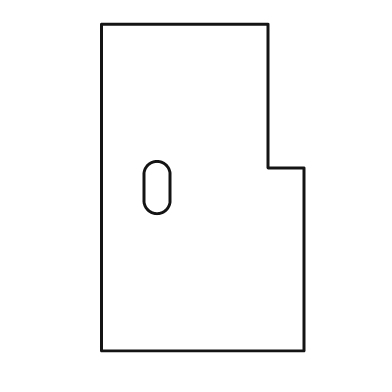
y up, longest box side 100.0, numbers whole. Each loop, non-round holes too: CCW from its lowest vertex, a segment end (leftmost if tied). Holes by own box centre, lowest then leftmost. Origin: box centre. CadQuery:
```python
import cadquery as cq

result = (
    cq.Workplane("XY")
    .moveTo(-31.0, -50.0)
    .lineTo(31.0, -50.0)
    .lineTo(31.0, 6.0)
    .lineTo(20.0, 6.0)
    .lineTo(20.0, 50.0)
    .lineTo(-31.0, 50.0)
    .close()
    .moveTo(-18.0, -4.0)
    .threePointArc((-14.0, -8.0), (-10.0, -4.0))
    .lineTo(-10.0, 4.0)
    .threePointArc((-14.0, 8.0), (-18.0, 4.0))
    .close()
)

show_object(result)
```